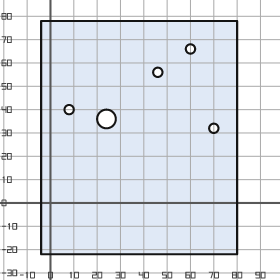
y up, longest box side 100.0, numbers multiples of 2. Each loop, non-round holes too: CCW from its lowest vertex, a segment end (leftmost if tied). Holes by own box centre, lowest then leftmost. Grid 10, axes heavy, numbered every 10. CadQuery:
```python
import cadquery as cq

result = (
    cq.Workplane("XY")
    .moveTo(-4.0, -22.0)
    .lineTo(80.0, -22.0)
    .lineTo(80.0, 78.0)
    .lineTo(-4.0, 78.0)
    .close()
    .moveTo(70.0, 32.0)
    .circle(2.0)
    .moveTo(24.0, 36.0)
    .circle(4.0)
    .moveTo(8.0, 40.0)
    .circle(2.0)
    .moveTo(46.0, 56.0)
    .circle(2.0)
    .moveTo(60.0, 66.0)
    .circle(2.0)
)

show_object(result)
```